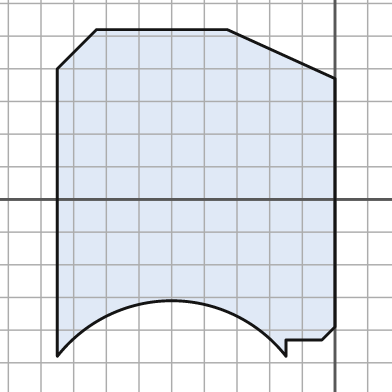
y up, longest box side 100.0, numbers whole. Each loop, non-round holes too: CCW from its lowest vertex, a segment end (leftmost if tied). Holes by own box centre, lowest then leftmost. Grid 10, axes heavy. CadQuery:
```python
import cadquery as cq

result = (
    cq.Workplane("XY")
    .moveTo(-85.0, -48.0)
    .threePointArc((-50.0, -31.0), (-15.0, -48.0))
    .lineTo(-15.0, -43.0)
    .lineTo(-4.0, -43.0)
    .lineTo(0.0, -39.0)
    .lineTo(0.0, 37.0)
    .lineTo(-33.0, 52.0)
    .lineTo(-73.0, 52.0)
    .lineTo(-85.0, 40.0)
    .close()
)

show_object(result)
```